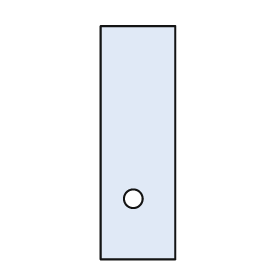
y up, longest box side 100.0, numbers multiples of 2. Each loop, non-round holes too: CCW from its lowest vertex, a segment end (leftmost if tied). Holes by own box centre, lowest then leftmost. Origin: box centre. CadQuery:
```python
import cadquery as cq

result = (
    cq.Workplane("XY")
    .moveTo(-16.0, -50.0)
    .lineTo(16.0, -50.0)
    .lineTo(16.0, 50.0)
    .lineTo(-16.0, 50.0)
    .close()
    .moveTo(-2.0, -24.0)
    .circle(4.0)
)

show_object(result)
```